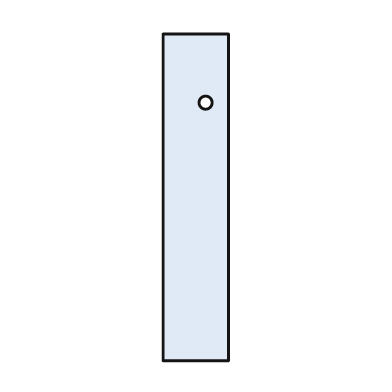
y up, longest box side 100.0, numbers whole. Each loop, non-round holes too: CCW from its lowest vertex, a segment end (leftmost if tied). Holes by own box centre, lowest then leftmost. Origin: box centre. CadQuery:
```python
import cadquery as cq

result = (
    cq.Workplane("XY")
    .moveTo(-10.0, -50.0)
    .lineTo(10.0, -50.0)
    .lineTo(10.0, 50.0)
    .lineTo(-10.0, 50.0)
    .close()
    .moveTo(3.0, 29.0)
    .circle(2.0)
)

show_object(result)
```